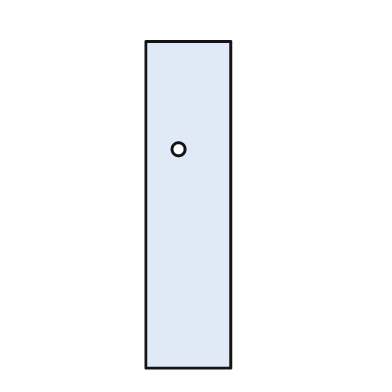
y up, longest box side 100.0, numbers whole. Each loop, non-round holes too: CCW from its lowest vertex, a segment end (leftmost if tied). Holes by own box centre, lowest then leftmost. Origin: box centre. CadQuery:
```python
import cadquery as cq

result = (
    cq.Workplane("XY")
    .moveTo(-13.0, -50.0)
    .lineTo(13.0, -50.0)
    .lineTo(13.0, 50.0)
    .lineTo(-13.0, 50.0)
    .close()
    .moveTo(-3.0, 17.0)
    .circle(2.0)
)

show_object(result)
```